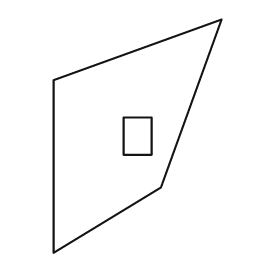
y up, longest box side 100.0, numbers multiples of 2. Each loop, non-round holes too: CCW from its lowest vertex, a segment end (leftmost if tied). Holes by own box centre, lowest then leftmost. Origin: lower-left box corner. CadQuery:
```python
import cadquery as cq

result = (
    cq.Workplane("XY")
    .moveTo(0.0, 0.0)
    .lineTo(46.0, 28.0)
    .lineTo(72.0, 100.0)
    .lineTo(0.0, 74.0)
    .close()
    .moveTo(30.0, 42.0)
    .lineTo(42.0, 42.0)
    .lineTo(42.0, 58.0)
    .lineTo(30.0, 58.0)
    .close()
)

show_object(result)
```